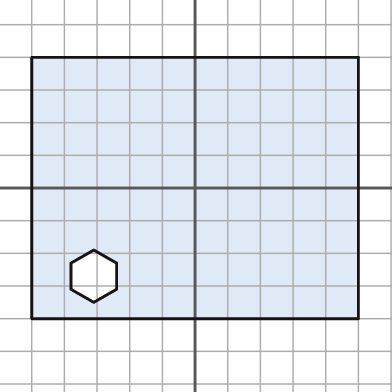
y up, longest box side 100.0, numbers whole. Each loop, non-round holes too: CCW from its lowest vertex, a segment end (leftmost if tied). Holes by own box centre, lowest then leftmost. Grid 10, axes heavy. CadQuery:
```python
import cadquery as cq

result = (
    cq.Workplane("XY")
    .moveTo(-50.0, -40.0)
    .lineTo(50.0, -40.0)
    .lineTo(50.0, 40.0)
    .lineTo(-50.0, 40.0)
    .close()
    .moveTo(-31.0, -35.0)
    .lineTo(-24.0, -31.0)
    .lineTo(-24.0, -23.0)
    .lineTo(-31.0, -19.0)
    .lineTo(-38.0, -23.0)
    .lineTo(-38.0, -31.0)
    .close()
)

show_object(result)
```